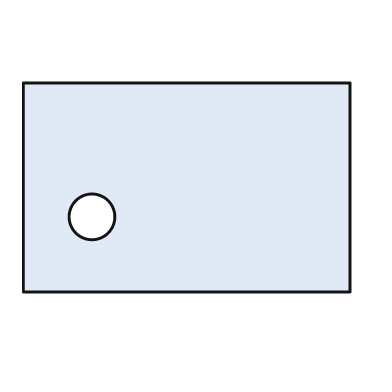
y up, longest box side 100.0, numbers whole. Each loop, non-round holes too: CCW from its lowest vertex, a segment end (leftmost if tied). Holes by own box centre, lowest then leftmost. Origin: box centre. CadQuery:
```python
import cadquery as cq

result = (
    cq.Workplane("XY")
    .moveTo(-50.0, -32.0)
    .lineTo(50.0, -32.0)
    .lineTo(50.0, 32.0)
    .lineTo(-50.0, 32.0)
    .close()
    .moveTo(-29.0, -9.0)
    .circle(7.0)
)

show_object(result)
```